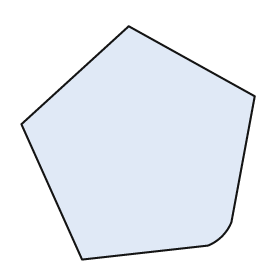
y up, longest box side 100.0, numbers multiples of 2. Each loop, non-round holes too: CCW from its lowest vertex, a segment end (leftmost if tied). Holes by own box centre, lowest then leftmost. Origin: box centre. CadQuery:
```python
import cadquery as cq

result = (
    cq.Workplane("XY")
    .moveTo(-24.0, -50.0)
    .lineTo(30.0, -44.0)
    .threePointArc((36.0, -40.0), (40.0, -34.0))
    .lineTo(50.0, 20.0)
    .lineTo(-4.0, 50.0)
    .lineTo(-50.0, 8.0)
    .close()
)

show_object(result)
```